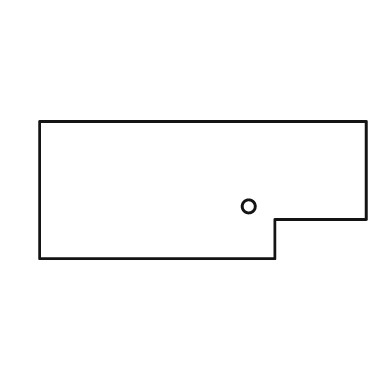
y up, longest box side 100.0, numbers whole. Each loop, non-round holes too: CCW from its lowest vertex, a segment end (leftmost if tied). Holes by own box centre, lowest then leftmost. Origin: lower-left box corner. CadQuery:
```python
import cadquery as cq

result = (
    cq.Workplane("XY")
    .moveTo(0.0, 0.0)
    .lineTo(72.0, 0.0)
    .lineTo(72.0, 12.0)
    .lineTo(100.0, 12.0)
    .lineTo(100.0, 42.0)
    .lineTo(0.0, 42.0)
    .close()
    .moveTo(64.0, 16.0)
    .circle(2.0)
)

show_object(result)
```